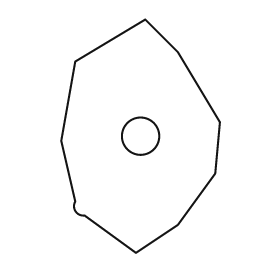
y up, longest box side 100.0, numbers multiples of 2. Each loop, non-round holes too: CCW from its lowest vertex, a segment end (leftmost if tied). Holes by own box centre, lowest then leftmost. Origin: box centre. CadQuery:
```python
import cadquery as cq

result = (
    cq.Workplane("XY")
    .moveTo(-2.0, -50.0)
    .lineTo(16.0, -38.0)
    .lineTo(32.0, -16.0)
    .lineTo(34.0, 6.0)
    .lineTo(16.0, 36.0)
    .lineTo(2.0, 50.0)
    .lineTo(-28.0, 32.0)
    .lineTo(-34.0, -2.0)
    .lineTo(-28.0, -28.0)
    .threePointArc((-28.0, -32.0), (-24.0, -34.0))
    .close()
    .moveTo(0.0, 0.0)
    .circle(8.0)
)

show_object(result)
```